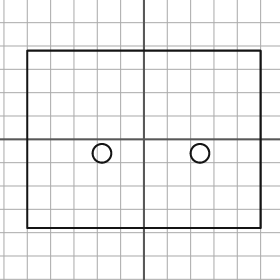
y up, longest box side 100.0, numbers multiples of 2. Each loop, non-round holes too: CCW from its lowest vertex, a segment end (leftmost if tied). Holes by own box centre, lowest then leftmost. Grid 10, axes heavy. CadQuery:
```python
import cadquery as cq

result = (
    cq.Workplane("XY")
    .moveTo(-50.0, -38.0)
    .lineTo(50.0, -38.0)
    .lineTo(50.0, 38.0)
    .lineTo(-50.0, 38.0)
    .close()
    .moveTo(-18.0, -6.0)
    .circle(4.0)
    .moveTo(24.0, -6.0)
    .circle(4.0)
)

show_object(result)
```